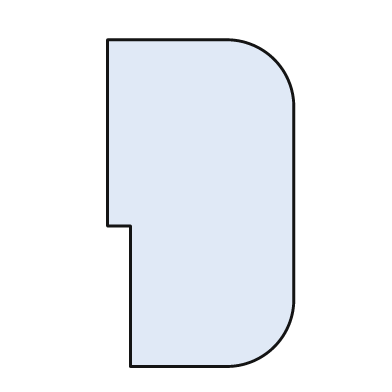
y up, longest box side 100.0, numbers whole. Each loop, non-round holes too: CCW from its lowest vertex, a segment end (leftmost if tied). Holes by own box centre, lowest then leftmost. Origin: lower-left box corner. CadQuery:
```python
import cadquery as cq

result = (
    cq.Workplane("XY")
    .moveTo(7.0, 0.0)
    .lineTo(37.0, 0.0)
    .threePointArc((51.0, 6.0), (57.0, 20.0))
    .lineTo(57.0, 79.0)
    .threePointArc((51.0, 94.0), (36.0, 100.0))
    .lineTo(0.0, 100.0)
    .lineTo(0.0, 43.0)
    .lineTo(7.0, 43.0)
    .close()
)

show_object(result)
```